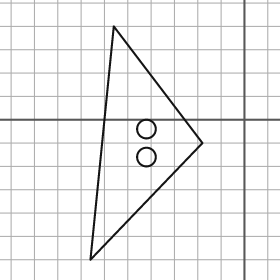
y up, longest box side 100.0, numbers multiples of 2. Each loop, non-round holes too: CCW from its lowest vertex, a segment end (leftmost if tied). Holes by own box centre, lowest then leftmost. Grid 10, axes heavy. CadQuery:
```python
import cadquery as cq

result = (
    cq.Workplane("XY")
    .moveTo(-66.0, -60.0)
    .lineTo(-18.0, -10.0)
    .lineTo(-56.0, 40.0)
    .close()
    .moveTo(-42.0, -16.0)
    .circle(4.0)
    .moveTo(-42.0, -4.0)
    .circle(4.0)
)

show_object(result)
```